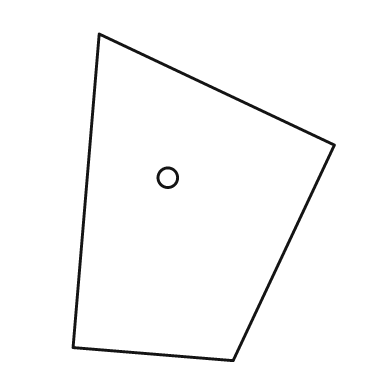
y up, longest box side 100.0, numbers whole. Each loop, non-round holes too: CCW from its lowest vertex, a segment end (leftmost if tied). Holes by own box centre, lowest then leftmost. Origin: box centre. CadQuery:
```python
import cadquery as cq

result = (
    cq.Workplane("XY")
    .moveTo(9.0, -50.0)
    .lineTo(40.0, 16.0)
    .lineTo(-32.0, 50.0)
    .lineTo(-40.0, -46.0)
    .close()
    .moveTo(-11.0, 6.0)
    .circle(3.0)
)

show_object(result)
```